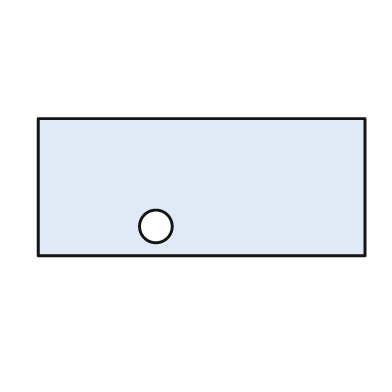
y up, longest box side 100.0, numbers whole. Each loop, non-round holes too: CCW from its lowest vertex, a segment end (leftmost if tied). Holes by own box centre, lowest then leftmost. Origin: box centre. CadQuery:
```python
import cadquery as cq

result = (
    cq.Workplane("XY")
    .moveTo(-50.0, -21.0)
    .lineTo(50.0, -21.0)
    .lineTo(50.0, 21.0)
    .lineTo(-50.0, 21.0)
    .close()
    .moveTo(-14.0, -12.0)
    .circle(5.0)
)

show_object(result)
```